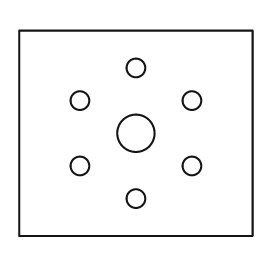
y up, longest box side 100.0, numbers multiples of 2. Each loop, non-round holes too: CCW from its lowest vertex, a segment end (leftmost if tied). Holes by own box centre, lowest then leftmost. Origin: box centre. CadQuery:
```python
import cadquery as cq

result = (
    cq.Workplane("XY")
    .moveTo(-50.0, -44.0)
    .lineTo(50.0, -44.0)
    .lineTo(50.0, 44.0)
    .lineTo(-50.0, 44.0)
    .close()
    .moveTo(0.0, -28.0)
    .circle(4.0)
    .moveTo(-24.0, -14.0)
    .circle(4.0)
    .moveTo(24.0, -14.0)
    .circle(4.0)
    .moveTo(0.0, 0.0)
    .circle(8.0)
    .moveTo(-24.0, 14.0)
    .circle(4.0)
    .moveTo(24.0, 14.0)
    .circle(4.0)
    .moveTo(0.0, 28.0)
    .circle(4.0)
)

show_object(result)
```